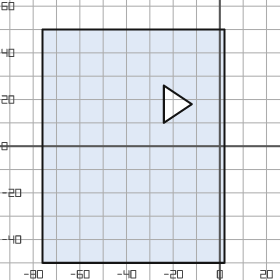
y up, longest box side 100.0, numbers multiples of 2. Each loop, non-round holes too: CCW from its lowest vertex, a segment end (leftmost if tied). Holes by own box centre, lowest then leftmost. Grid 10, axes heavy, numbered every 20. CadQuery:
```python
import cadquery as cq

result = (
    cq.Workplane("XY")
    .moveTo(-76.0, -50.0)
    .lineTo(2.0, -50.0)
    .lineTo(2.0, 50.0)
    .lineTo(-76.0, 50.0)
    .close()
    .moveTo(-24.0, 10.0)
    .lineTo(-12.0, 18.0)
    .lineTo(-24.0, 26.0)
    .close()
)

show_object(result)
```